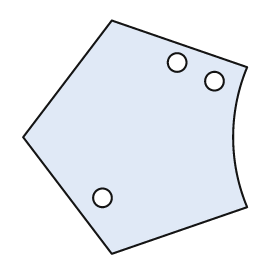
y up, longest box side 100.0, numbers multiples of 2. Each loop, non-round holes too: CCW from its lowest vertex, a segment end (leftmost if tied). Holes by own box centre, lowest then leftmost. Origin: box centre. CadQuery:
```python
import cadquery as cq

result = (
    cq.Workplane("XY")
    .moveTo(-10.0, -50.0)
    .lineTo(48.0, -30.0)
    .threePointArc((42.0, 0.0), (48.0, 30.0))
    .lineTo(-10.0, 50.0)
    .lineTo(-48.0, 0.0)
    .close()
    .moveTo(-14.0, -26.0)
    .circle(4.0)
    .moveTo(34.0, 24.0)
    .circle(4.0)
    .moveTo(18.0, 32.0)
    .circle(4.0)
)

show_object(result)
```